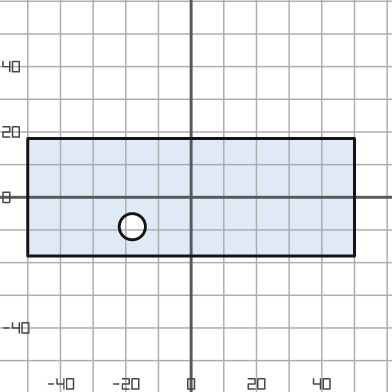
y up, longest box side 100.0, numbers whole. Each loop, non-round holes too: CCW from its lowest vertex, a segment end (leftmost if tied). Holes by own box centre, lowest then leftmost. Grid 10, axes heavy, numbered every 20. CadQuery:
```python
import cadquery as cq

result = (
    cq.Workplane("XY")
    .moveTo(-50.0, -18.0)
    .lineTo(50.0, -18.0)
    .lineTo(50.0, 18.0)
    .lineTo(-50.0, 18.0)
    .close()
    .moveTo(-18.0, -9.0)
    .circle(4.0)
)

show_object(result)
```